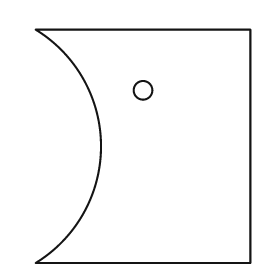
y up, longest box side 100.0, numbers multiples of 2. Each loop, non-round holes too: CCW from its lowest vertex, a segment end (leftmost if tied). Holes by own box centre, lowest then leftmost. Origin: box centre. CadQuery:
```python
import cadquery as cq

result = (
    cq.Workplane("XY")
    .moveTo(-46.0, -50.0)
    .lineTo(46.0, -50.0)
    .lineTo(46.0, 50.0)
    .lineTo(-46.0, 50.0)
    .threePointArc((-18.0, 0.0), (-46.0, -50.0))
    .close()
    .moveTo(0.0, 24.0)
    .circle(4.0)
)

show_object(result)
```